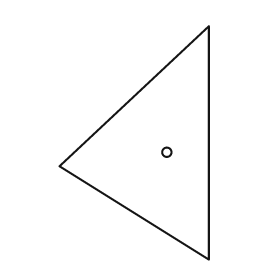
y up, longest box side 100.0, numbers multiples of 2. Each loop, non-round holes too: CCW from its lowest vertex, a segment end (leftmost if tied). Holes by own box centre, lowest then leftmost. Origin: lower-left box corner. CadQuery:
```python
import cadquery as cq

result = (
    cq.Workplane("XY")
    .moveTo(64.0, 0.0)
    .lineTo(64.0, 100.0)
    .lineTo(0.0, 40.0)
    .close()
    .moveTo(46.0, 46.0)
    .circle(2.0)
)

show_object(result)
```